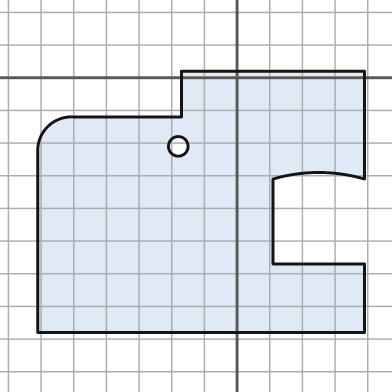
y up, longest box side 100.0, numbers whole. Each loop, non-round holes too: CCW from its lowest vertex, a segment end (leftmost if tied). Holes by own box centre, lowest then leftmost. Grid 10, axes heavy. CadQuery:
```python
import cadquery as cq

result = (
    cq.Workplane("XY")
    .moveTo(-61.0, -78.0)
    .lineTo(39.0, -78.0)
    .lineTo(39.0, -57.0)
    .lineTo(11.0, -57.0)
    .lineTo(11.0, -31.0)
    .threePointArc((25.0, -29.0), (39.0, -31.0))
    .lineTo(39.0, 2.0)
    .lineTo(-17.0, 2.0)
    .lineTo(-17.0, -12.0)
    .lineTo(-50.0, -12.0)
    .threePointArc((-58.0, -15.0), (-61.0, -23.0))
    .close()
    .moveTo(-18.0, -21.0)
    .circle(3.0)
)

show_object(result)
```